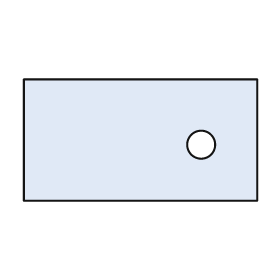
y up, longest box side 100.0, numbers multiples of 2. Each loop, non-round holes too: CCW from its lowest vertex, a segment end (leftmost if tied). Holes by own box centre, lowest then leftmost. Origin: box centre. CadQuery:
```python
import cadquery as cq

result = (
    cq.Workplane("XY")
    .moveTo(-50.0, -26.0)
    .lineTo(50.0, -26.0)
    .lineTo(50.0, 26.0)
    .lineTo(-50.0, 26.0)
    .close()
    .moveTo(26.0, -2.0)
    .circle(6.0)
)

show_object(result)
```